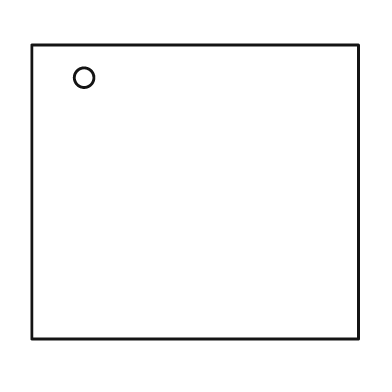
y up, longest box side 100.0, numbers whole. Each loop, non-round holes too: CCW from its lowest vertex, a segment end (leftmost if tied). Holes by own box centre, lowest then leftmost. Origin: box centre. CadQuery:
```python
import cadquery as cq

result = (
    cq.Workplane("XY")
    .moveTo(-50.0, -45.0)
    .lineTo(50.0, -45.0)
    .lineTo(50.0, 45.0)
    .lineTo(-50.0, 45.0)
    .close()
    .moveTo(-34.0, 35.0)
    .circle(3.0)
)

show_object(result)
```